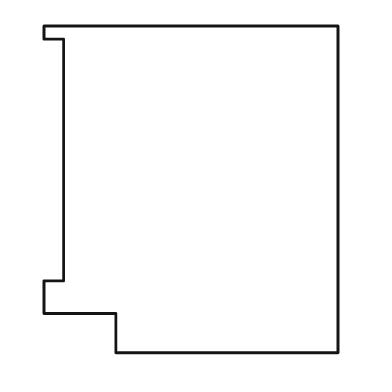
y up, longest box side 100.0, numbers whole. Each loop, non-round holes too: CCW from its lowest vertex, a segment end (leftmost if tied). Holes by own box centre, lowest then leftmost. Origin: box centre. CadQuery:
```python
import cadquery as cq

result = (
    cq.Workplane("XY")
    .moveTo(-23.0, -50.0)
    .lineTo(45.0, -50.0)
    .lineTo(45.0, 50.0)
    .lineTo(-45.0, 50.0)
    .lineTo(-45.0, 46.0)
    .lineTo(-39.0, 46.0)
    .lineTo(-39.0, -28.0)
    .lineTo(-45.0, -28.0)
    .lineTo(-45.0, -38.0)
    .lineTo(-23.0, -38.0)
    .close()
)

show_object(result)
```